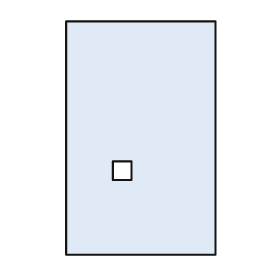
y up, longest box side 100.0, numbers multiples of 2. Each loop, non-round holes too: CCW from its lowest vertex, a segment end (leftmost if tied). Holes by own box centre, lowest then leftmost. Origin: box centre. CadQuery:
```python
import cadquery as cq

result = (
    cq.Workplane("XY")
    .moveTo(-32.0, -50.0)
    .lineTo(32.0, -50.0)
    .lineTo(32.0, 50.0)
    .lineTo(-32.0, 50.0)
    .close()
    .moveTo(-12.0, -18.0)
    .lineTo(-4.0, -18.0)
    .lineTo(-4.0, -10.0)
    .lineTo(-12.0, -10.0)
    .close()
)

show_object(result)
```